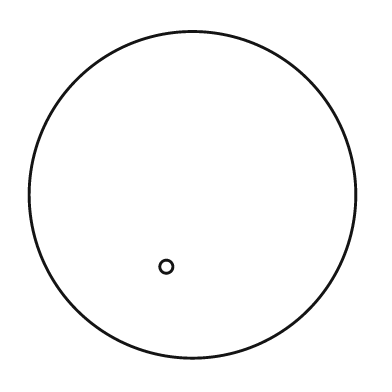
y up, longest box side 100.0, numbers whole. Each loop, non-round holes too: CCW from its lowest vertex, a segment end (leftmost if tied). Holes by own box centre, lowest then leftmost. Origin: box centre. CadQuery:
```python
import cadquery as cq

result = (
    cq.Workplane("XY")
    .moveTo(0.0, 0.0)
    .circle(50.0)
    .moveTo(-8.0, -22.0)
    .circle(2.0)
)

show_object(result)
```